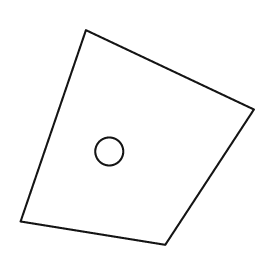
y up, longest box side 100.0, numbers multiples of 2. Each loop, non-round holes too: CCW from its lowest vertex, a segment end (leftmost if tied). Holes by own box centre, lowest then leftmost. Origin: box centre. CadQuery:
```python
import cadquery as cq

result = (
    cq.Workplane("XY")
    .moveTo(12.0, -46.0)
    .lineTo(50.0, 12.0)
    .lineTo(-22.0, 46.0)
    .lineTo(-50.0, -36.0)
    .close()
    .moveTo(-12.0, -6.0)
    .circle(6.0)
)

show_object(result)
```